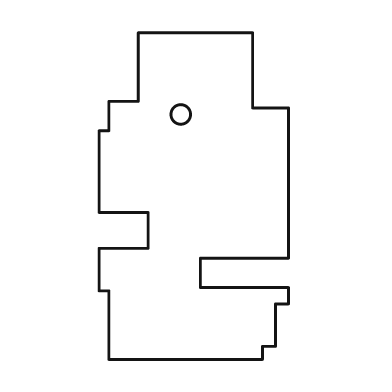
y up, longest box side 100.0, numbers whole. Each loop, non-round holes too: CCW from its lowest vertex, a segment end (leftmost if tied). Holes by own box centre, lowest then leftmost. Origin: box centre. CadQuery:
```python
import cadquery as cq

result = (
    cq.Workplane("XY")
    .moveTo(-26.0, -50.0)
    .lineTo(21.0, -50.0)
    .lineTo(21.0, -46.0)
    .lineTo(25.0, -46.0)
    .lineTo(25.0, -33.0)
    .lineTo(29.0, -33.0)
    .lineTo(29.0, -28.0)
    .lineTo(2.0, -28.0)
    .lineTo(2.0, -19.0)
    .lineTo(29.0, -19.0)
    .lineTo(29.0, 27.0)
    .lineTo(18.0, 27.0)
    .lineTo(18.0, 50.0)
    .lineTo(-17.0, 50.0)
    .lineTo(-17.0, 29.0)
    .lineTo(-26.0, 29.0)
    .lineTo(-26.0, 20.0)
    .lineTo(-29.0, 20.0)
    .lineTo(-29.0, -5.0)
    .lineTo(-14.0, -5.0)
    .lineTo(-14.0, -16.0)
    .lineTo(-29.0, -16.0)
    .lineTo(-29.0, -29.0)
    .lineTo(-26.0, -29.0)
    .close()
    .moveTo(-4.0, 25.0)
    .circle(3.0)
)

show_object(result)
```